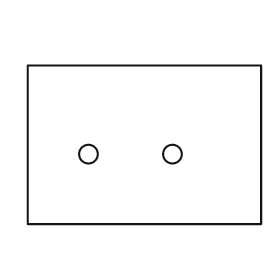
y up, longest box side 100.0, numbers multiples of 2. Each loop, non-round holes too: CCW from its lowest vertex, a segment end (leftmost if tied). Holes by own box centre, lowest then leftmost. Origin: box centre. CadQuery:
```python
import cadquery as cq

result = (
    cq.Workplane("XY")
    .moveTo(-50.0, -34.0)
    .lineTo(50.0, -34.0)
    .lineTo(50.0, 34.0)
    .lineTo(-50.0, 34.0)
    .close()
    .moveTo(-24.0, -4.0)
    .circle(4.0)
    .moveTo(12.0, -4.0)
    .circle(4.0)
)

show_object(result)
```